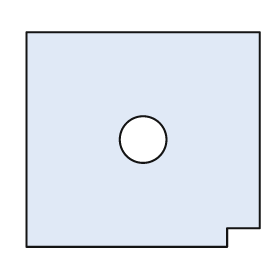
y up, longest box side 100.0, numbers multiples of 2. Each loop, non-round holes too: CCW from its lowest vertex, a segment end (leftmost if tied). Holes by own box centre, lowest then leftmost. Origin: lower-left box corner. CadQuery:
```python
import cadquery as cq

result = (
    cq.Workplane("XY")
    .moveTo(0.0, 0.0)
    .lineTo(86.0, 0.0)
    .lineTo(86.0, 8.0)
    .lineTo(100.0, 8.0)
    .lineTo(100.0, 92.0)
    .lineTo(0.0, 92.0)
    .close()
    .moveTo(50.0, 46.0)
    .circle(10.0)
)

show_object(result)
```